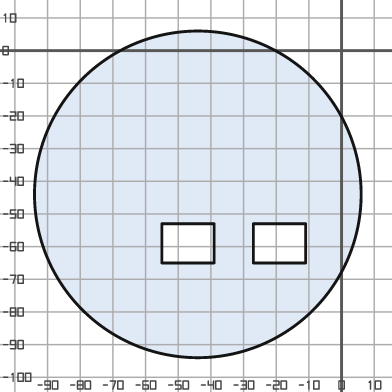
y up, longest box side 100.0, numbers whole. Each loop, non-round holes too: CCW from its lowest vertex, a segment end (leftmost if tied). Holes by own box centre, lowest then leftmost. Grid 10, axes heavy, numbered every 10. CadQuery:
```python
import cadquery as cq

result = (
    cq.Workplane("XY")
    .moveTo(-44.0, -44.0)
    .circle(50.0)
    .moveTo(-55.0, -65.0)
    .lineTo(-39.0, -65.0)
    .lineTo(-39.0, -53.0)
    .lineTo(-55.0, -53.0)
    .close()
    .moveTo(-27.0, -65.0)
    .lineTo(-11.0, -65.0)
    .lineTo(-11.0, -53.0)
    .lineTo(-27.0, -53.0)
    .close()
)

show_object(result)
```